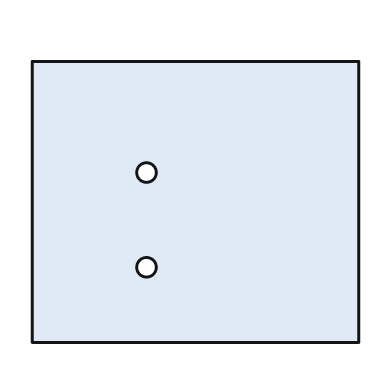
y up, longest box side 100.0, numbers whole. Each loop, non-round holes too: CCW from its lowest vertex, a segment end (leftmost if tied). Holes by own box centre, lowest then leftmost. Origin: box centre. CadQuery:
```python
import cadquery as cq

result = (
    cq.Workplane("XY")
    .moveTo(-50.0, -43.0)
    .lineTo(50.0, -43.0)
    .lineTo(50.0, 43.0)
    .lineTo(-50.0, 43.0)
    .close()
    .moveTo(-15.0, -20.0)
    .circle(3.0)
    .moveTo(-15.0, 9.0)
    .circle(3.0)
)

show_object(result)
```